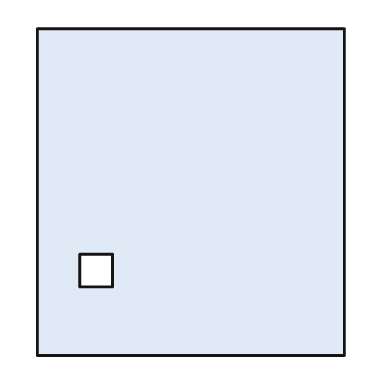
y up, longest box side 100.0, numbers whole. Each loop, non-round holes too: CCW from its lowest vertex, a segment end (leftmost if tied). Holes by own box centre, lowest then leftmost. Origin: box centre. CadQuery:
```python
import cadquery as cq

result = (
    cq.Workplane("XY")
    .moveTo(-47.0, -50.0)
    .lineTo(47.0, -50.0)
    .lineTo(47.0, 50.0)
    .lineTo(-47.0, 50.0)
    .close()
    .moveTo(-34.0, -29.0)
    .lineTo(-24.0, -29.0)
    .lineTo(-24.0, -19.0)
    .lineTo(-34.0, -19.0)
    .close()
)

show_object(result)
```